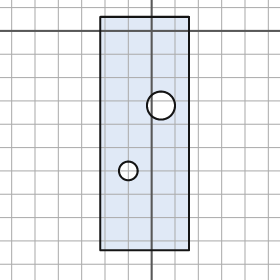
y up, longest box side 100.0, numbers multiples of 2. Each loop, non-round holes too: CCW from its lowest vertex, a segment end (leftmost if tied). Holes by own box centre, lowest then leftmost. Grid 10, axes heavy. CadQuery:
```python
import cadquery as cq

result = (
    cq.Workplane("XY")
    .moveTo(-22.0, -94.0)
    .lineTo(16.0, -94.0)
    .lineTo(16.0, 6.0)
    .lineTo(-22.0, 6.0)
    .close()
    .moveTo(-10.0, -60.0)
    .circle(4.0)
    .moveTo(4.0, -32.0)
    .circle(6.0)
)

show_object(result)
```